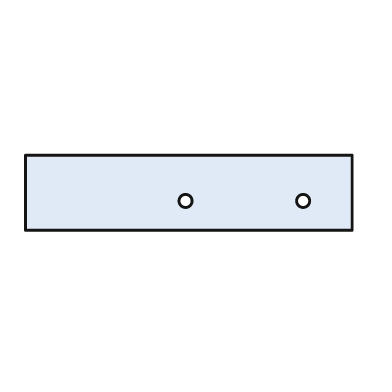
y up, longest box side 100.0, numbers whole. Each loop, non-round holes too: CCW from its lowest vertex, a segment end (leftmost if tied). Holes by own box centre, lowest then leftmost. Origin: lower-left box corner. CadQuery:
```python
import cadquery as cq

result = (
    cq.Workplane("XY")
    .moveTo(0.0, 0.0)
    .lineTo(100.0, 0.0)
    .lineTo(100.0, 23.0)
    .lineTo(0.0, 23.0)
    .close()
    .moveTo(49.0, 9.0)
    .circle(2.0)
    .moveTo(85.0, 9.0)
    .circle(2.0)
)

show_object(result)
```